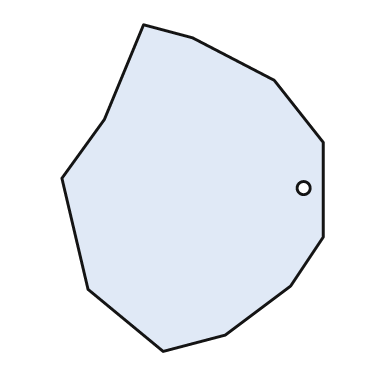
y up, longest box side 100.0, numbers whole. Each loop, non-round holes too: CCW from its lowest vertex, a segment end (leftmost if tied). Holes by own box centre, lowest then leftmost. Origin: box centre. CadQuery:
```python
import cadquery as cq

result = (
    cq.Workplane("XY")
    .moveTo(-9.0, -50.0)
    .lineTo(10.0, -45.0)
    .lineTo(30.0, -30.0)
    .lineTo(40.0, -15.0)
    .lineTo(40.0, 14.0)
    .lineTo(25.0, 33.0)
    .lineTo(0.0, 46.0)
    .lineTo(-15.0, 50.0)
    .lineTo(-27.0, 21.0)
    .lineTo(-40.0, 3.0)
    .lineTo(-32.0, -31.0)
    .close()
    .moveTo(34.0, 0.0)
    .circle(2.0)
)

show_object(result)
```